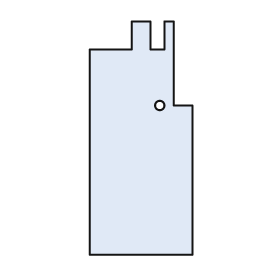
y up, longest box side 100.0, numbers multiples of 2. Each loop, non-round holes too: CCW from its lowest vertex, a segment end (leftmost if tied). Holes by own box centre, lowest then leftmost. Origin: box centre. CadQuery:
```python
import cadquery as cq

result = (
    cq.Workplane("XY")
    .moveTo(-22.0, -50.0)
    .lineTo(22.0, -50.0)
    .lineTo(22.0, 14.0)
    .lineTo(14.0, 14.0)
    .lineTo(14.0, 50.0)
    .lineTo(10.0, 50.0)
    .lineTo(10.0, 38.0)
    .lineTo(4.0, 38.0)
    .lineTo(4.0, 50.0)
    .lineTo(-4.0, 50.0)
    .lineTo(-4.0, 38.0)
    .lineTo(-22.0, 38.0)
    .close()
    .moveTo(8.0, 14.0)
    .circle(2.0)
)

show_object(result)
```